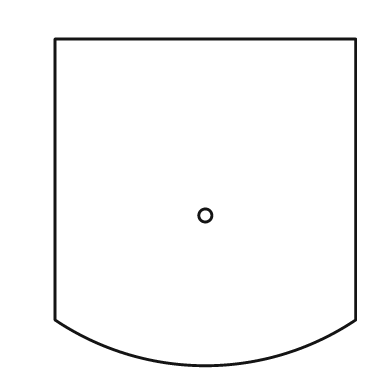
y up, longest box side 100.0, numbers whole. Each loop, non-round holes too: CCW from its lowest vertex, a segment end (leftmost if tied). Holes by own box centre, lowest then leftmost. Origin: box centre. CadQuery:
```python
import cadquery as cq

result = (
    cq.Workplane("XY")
    .moveTo(-46.0, -36.0)
    .threePointArc((0.0, -50.0), (46.0, -36.0))
    .lineTo(46.0, 50.0)
    .lineTo(-46.0, 50.0)
    .close()
    .moveTo(0.0, -4.0)
    .circle(2.0)
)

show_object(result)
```